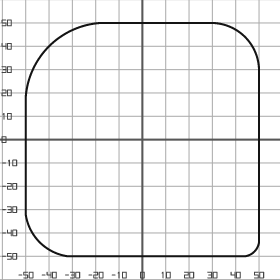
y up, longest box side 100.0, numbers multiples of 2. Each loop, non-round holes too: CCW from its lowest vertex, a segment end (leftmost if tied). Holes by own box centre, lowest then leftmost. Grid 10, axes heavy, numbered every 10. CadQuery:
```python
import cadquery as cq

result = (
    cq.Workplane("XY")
    .moveTo(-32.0, -50.0)
    .lineTo(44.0, -50.0)
    .threePointArc((48.0, -48.0), (50.0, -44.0))
    .lineTo(50.0, 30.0)
    .threePointArc((44.0, 44.0), (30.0, 50.0))
    .lineTo(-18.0, 50.0)
    .threePointArc((-40.0, 40.0), (-50.0, 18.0))
    .lineTo(-50.0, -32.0)
    .threePointArc((-44.0, -44.0), (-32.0, -50.0))
    .close()
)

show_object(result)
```